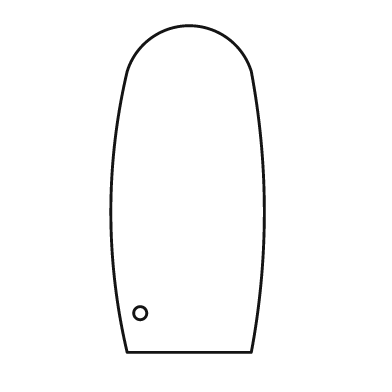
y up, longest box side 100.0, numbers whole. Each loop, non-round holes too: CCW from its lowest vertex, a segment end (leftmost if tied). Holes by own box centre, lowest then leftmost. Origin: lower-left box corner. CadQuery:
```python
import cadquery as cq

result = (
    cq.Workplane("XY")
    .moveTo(5.0, 0.0)
    .lineTo(43.0, 0.0)
    .threePointArc((47.0, 43.0), (43.0, 86.0))
    .threePointArc((24.0, 100.0), (5.0, 86.0))
    .threePointArc((0.0, 43.0), (5.0, 0.0))
    .close()
    .moveTo(9.0, 12.0)
    .circle(2.0)
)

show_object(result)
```